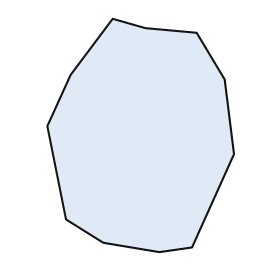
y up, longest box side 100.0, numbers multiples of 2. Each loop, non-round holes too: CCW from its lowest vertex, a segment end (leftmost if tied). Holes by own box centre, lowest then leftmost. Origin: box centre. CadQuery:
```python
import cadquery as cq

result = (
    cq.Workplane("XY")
    .moveTo(8.0, -50.0)
    .lineTo(22.0, -48.0)
    .lineTo(40.0, -8.0)
    .lineTo(36.0, 24.0)
    .lineTo(24.0, 44.0)
    .lineTo(2.0, 46.0)
    .lineTo(-12.0, 50.0)
    .lineTo(-30.0, 26.0)
    .lineTo(-40.0, 4.0)
    .lineTo(-32.0, -36.0)
    .lineTo(-16.0, -46.0)
    .close()
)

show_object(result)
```